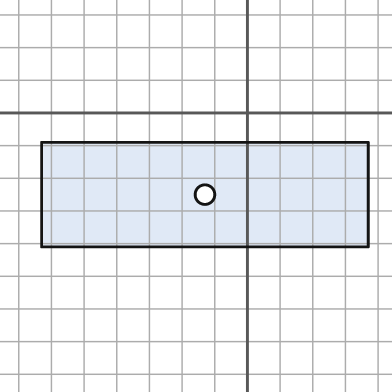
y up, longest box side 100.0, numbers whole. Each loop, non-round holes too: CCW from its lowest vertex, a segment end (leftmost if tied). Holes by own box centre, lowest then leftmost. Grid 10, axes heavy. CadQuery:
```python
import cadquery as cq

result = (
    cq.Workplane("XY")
    .moveTo(-63.0, -41.0)
    .lineTo(37.0, -41.0)
    .lineTo(37.0, -9.0)
    .lineTo(-63.0, -9.0)
    .close()
    .moveTo(-13.0, -25.0)
    .circle(3.0)
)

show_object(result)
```